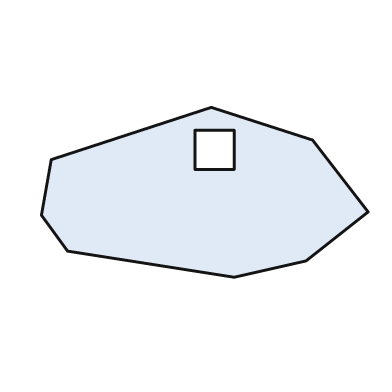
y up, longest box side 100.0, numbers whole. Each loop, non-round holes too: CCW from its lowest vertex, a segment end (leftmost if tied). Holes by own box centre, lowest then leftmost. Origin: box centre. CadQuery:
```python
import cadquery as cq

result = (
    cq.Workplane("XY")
    .moveTo(9.0, -26.0)
    .lineTo(31.0, -21.0)
    .lineTo(50.0, -6.0)
    .lineTo(33.0, 16.0)
    .lineTo(2.0, 26.0)
    .lineTo(-47.0, 10.0)
    .lineTo(-50.0, -7.0)
    .lineTo(-42.0, -18.0)
    .close()
    .moveTo(-3.0, 7.0)
    .lineTo(9.0, 7.0)
    .lineTo(9.0, 19.0)
    .lineTo(-3.0, 19.0)
    .close()
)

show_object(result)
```